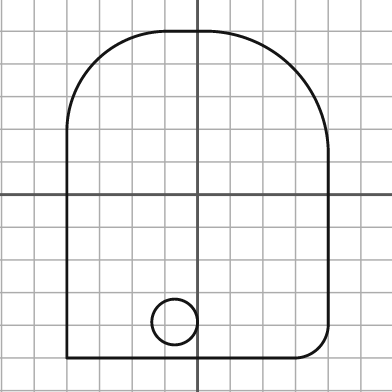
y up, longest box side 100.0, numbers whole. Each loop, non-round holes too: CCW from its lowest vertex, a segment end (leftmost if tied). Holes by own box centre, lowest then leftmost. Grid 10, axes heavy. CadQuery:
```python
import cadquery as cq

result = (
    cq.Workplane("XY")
    .moveTo(-40.0, -50.0)
    .lineTo(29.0, -50.0)
    .threePointArc((37.0, -47.0), (40.0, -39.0))
    .lineTo(40.0, 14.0)
    .threePointArc((29.0, 39.0), (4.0, 50.0))
    .lineTo(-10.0, 50.0)
    .threePointArc((-31.0, 41.0), (-40.0, 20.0))
    .close()
    .moveTo(-7.0, -39.0)
    .circle(7.0)
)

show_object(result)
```